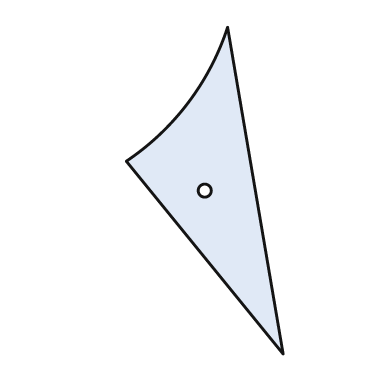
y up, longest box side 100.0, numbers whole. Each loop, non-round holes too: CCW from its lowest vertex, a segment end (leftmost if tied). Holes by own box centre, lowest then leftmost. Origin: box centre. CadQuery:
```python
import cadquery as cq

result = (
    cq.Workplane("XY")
    .moveTo(24.0, -50.0)
    .lineTo(7.0, 50.0)
    .threePointArc((-5.0, 27.0), (-24.0, 9.0))
    .close()
    .moveTo(0.0, 0.0)
    .circle(2.0)
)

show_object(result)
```